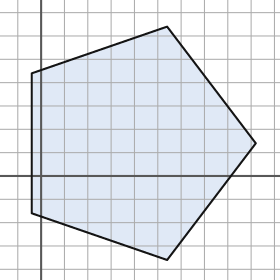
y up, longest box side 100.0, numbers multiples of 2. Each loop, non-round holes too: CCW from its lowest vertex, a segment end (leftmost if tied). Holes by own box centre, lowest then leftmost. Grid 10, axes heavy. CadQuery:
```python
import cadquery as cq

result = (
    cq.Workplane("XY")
    .moveTo(54.0, -36.0)
    .lineTo(92.0, 14.0)
    .lineTo(54.0, 64.0)
    .lineTo(-4.0, 44.0)
    .lineTo(-4.0, -16.0)
    .close()
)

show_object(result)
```